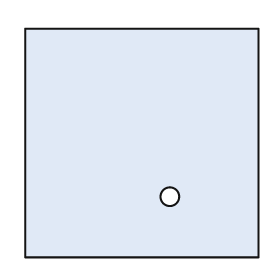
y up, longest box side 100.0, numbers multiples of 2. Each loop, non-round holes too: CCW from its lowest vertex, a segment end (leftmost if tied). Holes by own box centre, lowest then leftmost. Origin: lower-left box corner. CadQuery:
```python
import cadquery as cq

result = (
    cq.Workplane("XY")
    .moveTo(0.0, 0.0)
    .lineTo(100.0, 0.0)
    .lineTo(100.0, 98.0)
    .lineTo(0.0, 98.0)
    .close()
    .moveTo(62.0, 26.0)
    .circle(4.0)
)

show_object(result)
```